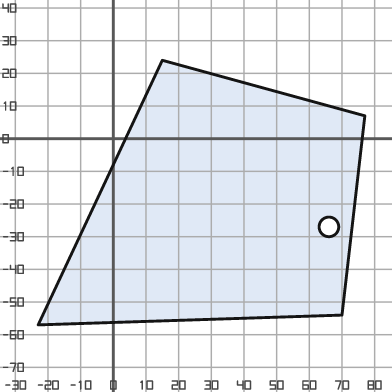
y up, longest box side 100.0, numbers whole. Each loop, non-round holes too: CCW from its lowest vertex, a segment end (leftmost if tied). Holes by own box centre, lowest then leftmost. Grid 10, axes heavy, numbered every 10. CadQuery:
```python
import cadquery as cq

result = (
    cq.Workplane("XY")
    .moveTo(-23.0, -57.0)
    .lineTo(70.0, -54.0)
    .lineTo(77.0, 7.0)
    .lineTo(15.0, 24.0)
    .close()
    .moveTo(66.0, -27.0)
    .circle(3.0)
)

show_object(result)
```